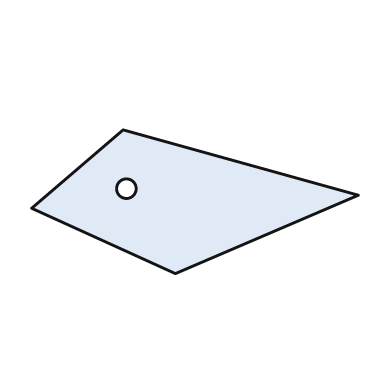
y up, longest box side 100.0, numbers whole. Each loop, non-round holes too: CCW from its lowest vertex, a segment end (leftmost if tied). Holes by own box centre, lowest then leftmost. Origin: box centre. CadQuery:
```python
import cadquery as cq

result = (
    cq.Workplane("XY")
    .moveTo(-6.0, -22.0)
    .lineTo(50.0, 2.0)
    .lineTo(-22.0, 22.0)
    .lineTo(-50.0, -2.0)
    .close()
    .moveTo(-21.0, 4.0)
    .circle(3.0)
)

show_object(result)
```